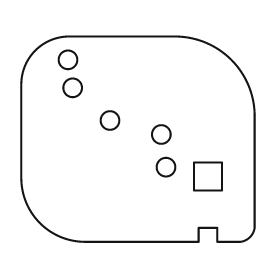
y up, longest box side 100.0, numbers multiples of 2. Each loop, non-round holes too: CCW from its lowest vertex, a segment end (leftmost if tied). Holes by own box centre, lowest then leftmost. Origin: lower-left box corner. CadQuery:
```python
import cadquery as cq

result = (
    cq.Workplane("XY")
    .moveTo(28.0, 0.0)
    .lineTo(76.0, 0.0)
    .lineTo(76.0, 6.0)
    .lineTo(84.0, 6.0)
    .lineTo(84.0, 0.0)
    .lineTo(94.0, 0.0)
    .threePointArc((98.0, 2.0), (100.0, 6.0))
    .lineTo(100.0, 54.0)
    .threePointArc((90.0, 78.0), (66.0, 88.0))
    .lineTo(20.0, 88.0)
    .threePointArc((6.0, 82.0), (0.0, 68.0))
    .lineTo(0.0, 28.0)
    .threePointArc((8.0, 8.0), (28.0, 0.0))
    .close()
    .moveTo(74.0, 22.0)
    .lineTo(86.0, 22.0)
    .lineTo(86.0, 34.0)
    .lineTo(74.0, 34.0)
    .close()
    .moveTo(62.0, 32.0)
    .circle(4.0)
    .moveTo(60.0, 46.0)
    .circle(4.0)
    .moveTo(38.0, 52.0)
    .circle(4.0)
    .moveTo(22.0, 66.0)
    .circle(4.0)
    .moveTo(20.0, 78.0)
    .circle(4.0)
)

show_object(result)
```